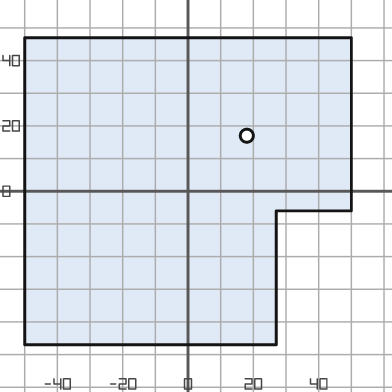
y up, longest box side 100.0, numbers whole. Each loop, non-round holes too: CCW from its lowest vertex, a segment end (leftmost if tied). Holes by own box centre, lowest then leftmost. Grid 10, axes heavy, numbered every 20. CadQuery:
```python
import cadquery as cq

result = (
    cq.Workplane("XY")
    .moveTo(-50.0, -47.0)
    .lineTo(27.0, -47.0)
    .lineTo(27.0, -6.0)
    .lineTo(50.0, -6.0)
    .lineTo(50.0, 47.0)
    .lineTo(-50.0, 47.0)
    .close()
    .moveTo(18.0, 17.0)
    .circle(2.0)
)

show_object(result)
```